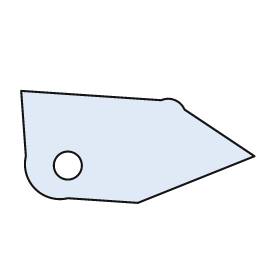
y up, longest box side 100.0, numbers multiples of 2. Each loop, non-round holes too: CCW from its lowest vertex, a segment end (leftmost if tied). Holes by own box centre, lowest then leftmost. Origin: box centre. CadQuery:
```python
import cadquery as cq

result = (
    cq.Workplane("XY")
    .moveTo(0.0, -24.0)
    .lineTo(50.0, -4.0)
    .lineTo(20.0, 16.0)
    .threePointArc((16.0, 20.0), (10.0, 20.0))
    .lineTo(-50.0, 24.0)
    .lineTo(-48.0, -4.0)
    .threePointArc((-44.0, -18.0), (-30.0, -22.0))
    .close()
    .moveTo(-30.0, -8.0)
    .circle(6.0)
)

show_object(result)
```